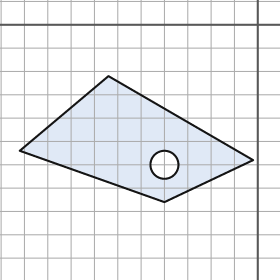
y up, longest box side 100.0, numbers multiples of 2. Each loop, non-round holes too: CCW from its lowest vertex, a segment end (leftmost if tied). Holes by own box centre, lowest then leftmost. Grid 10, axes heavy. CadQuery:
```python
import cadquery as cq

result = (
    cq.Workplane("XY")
    .moveTo(-40.0, -76.0)
    .lineTo(-2.0, -58.0)
    .lineTo(-64.0, -22.0)
    .lineTo(-102.0, -54.0)
    .close()
    .moveTo(-40.0, -60.0)
    .circle(6.0)
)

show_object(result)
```